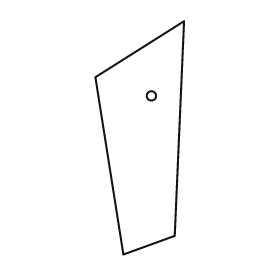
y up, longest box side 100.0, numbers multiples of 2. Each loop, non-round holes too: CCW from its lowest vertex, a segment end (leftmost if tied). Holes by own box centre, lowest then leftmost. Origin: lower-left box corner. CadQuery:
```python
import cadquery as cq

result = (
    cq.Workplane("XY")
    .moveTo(12.0, 0.0)
    .lineTo(34.0, 8.0)
    .lineTo(38.0, 100.0)
    .lineTo(0.0, 76.0)
    .close()
    .moveTo(24.0, 68.0)
    .circle(2.0)
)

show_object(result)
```